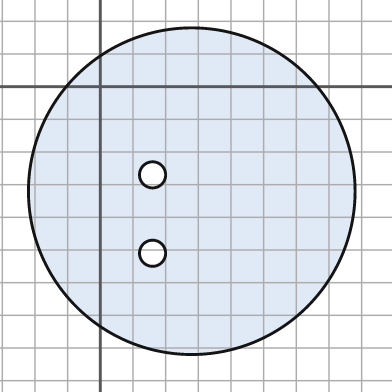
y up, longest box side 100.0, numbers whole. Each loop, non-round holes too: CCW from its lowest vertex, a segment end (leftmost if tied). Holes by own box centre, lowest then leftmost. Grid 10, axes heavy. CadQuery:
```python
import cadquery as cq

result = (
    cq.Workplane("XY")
    .moveTo(28.0, -32.0)
    .circle(50.0)
    .moveTo(16.0, -51.0)
    .circle(4.0)
    .moveTo(16.0, -27.0)
    .circle(4.0)
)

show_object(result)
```